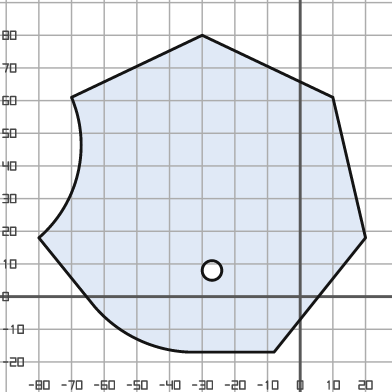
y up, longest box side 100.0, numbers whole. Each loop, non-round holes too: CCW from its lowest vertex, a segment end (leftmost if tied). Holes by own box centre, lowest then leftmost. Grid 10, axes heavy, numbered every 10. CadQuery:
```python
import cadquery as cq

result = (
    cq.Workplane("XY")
    .moveTo(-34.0, -17.0)
    .lineTo(-8.0, -17.0)
    .lineTo(20.0, 18.0)
    .lineTo(10.0, 61.0)
    .lineTo(-30.0, 80.0)
    .lineTo(-70.0, 61.0)
    .threePointArc((-68.0, 38.0), (-80.0, 18.0))
    .lineTo(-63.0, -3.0)
    .threePointArc((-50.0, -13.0), (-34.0, -17.0))
    .close()
    .moveTo(-27.0, 8.0)
    .circle(3.0)
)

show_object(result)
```